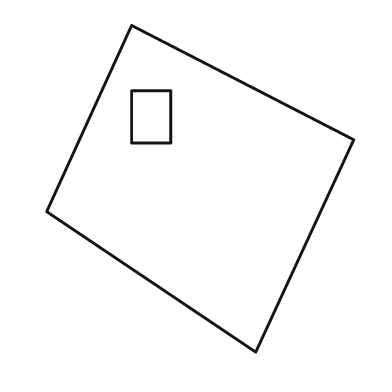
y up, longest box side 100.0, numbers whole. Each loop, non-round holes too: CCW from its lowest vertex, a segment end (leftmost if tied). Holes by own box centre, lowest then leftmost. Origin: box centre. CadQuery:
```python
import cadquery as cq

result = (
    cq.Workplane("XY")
    .moveTo(17.0, -50.0)
    .lineTo(47.0, 15.0)
    .lineTo(-21.0, 50.0)
    .lineTo(-47.0, -7.0)
    .close()
    .moveTo(-21.0, 14.0)
    .lineTo(-9.0, 14.0)
    .lineTo(-9.0, 30.0)
    .lineTo(-21.0, 30.0)
    .close()
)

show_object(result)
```